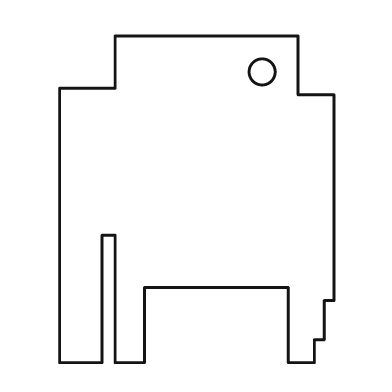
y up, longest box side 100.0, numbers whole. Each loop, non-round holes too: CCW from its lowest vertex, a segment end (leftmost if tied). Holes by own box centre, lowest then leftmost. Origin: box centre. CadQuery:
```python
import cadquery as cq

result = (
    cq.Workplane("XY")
    .moveTo(-42.0, -50.0)
    .lineTo(-29.0, -50.0)
    .lineTo(-29.0, -11.0)
    .lineTo(-25.0, -11.0)
    .lineTo(-25.0, -50.0)
    .lineTo(-16.0, -50.0)
    .lineTo(-16.0, -27.0)
    .lineTo(28.0, -27.0)
    .lineTo(28.0, -50.0)
    .lineTo(36.0, -50.0)
    .lineTo(36.0, -43.0)
    .lineTo(39.0, -43.0)
    .lineTo(39.0, -31.0)
    .lineTo(42.0, -31.0)
    .lineTo(42.0, 32.0)
    .lineTo(31.0, 32.0)
    .lineTo(31.0, 50.0)
    .lineTo(-25.0, 50.0)
    .lineTo(-25.0, 34.0)
    .lineTo(-42.0, 34.0)
    .close()
    .moveTo(20.0, 39.0)
    .circle(4.0)
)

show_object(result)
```